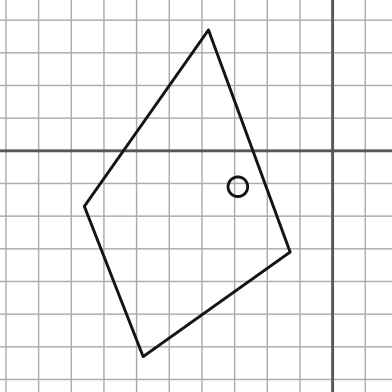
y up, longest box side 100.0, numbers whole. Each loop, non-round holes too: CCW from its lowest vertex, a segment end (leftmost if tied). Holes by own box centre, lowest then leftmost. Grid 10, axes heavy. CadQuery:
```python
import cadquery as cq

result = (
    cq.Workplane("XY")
    .moveTo(-58.0, -63.0)
    .lineTo(-13.0, -31.0)
    .lineTo(-38.0, 37.0)
    .lineTo(-76.0, -17.0)
    .close()
    .moveTo(-29.0, -11.0)
    .circle(3.0)
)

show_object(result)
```